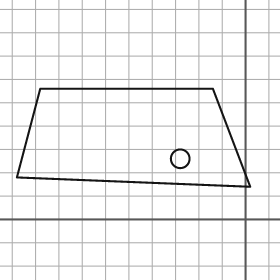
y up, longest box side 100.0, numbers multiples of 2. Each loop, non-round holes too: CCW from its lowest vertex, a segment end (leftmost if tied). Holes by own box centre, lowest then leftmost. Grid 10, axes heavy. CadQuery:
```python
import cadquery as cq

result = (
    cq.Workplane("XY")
    .moveTo(2.0, 14.0)
    .lineTo(-14.0, 56.0)
    .lineTo(-88.0, 56.0)
    .lineTo(-98.0, 18.0)
    .close()
    .moveTo(-28.0, 26.0)
    .circle(4.0)
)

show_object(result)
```